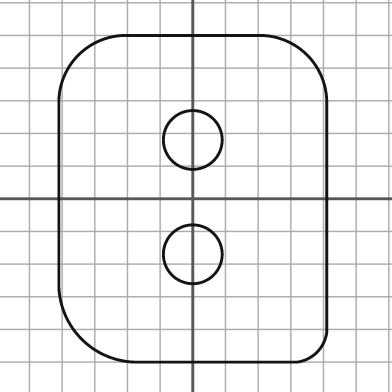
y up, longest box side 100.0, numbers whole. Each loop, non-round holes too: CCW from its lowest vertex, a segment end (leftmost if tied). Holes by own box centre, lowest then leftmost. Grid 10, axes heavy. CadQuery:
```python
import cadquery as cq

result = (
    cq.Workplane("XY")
    .moveTo(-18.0, -50.0)
    .lineTo(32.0, -50.0)
    .threePointArc((38.0, -47.0), (41.0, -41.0))
    .lineTo(41.0, 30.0)
    .threePointArc((35.0, 44.0), (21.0, 50.0))
    .lineTo(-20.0, 50.0)
    .threePointArc((-35.0, 44.0), (-41.0, 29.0))
    .lineTo(-41.0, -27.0)
    .threePointArc((-34.0, -43.0), (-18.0, -50.0))
    .close()
    .moveTo(0.0, -17.0)
    .circle(9.0)
    .moveTo(0.0, 18.0)
    .circle(9.0)
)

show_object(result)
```